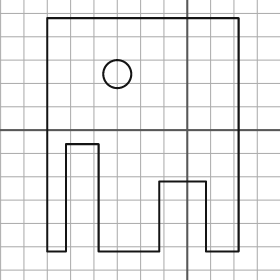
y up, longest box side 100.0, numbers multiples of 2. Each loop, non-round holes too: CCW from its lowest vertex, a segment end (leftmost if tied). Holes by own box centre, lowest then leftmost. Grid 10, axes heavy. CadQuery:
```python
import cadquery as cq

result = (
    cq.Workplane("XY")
    .moveTo(-60.0, -52.0)
    .lineTo(-52.0, -52.0)
    .lineTo(-52.0, -6.0)
    .lineTo(-38.0, -6.0)
    .lineTo(-38.0, -52.0)
    .lineTo(-12.0, -52.0)
    .lineTo(-12.0, -22.0)
    .lineTo(8.0, -22.0)
    .lineTo(8.0, -52.0)
    .lineTo(22.0, -52.0)
    .lineTo(22.0, 48.0)
    .lineTo(-60.0, 48.0)
    .close()
    .moveTo(-30.0, 24.0)
    .circle(6.0)
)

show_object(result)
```